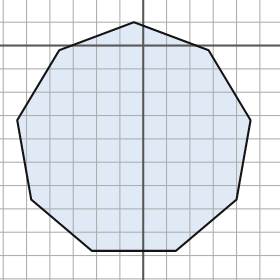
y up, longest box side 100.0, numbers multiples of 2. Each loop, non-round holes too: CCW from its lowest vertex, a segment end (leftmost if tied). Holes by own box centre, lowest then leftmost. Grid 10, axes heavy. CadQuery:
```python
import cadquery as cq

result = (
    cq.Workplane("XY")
    .moveTo(-22.0, -88.0)
    .lineTo(14.0, -88.0)
    .lineTo(40.0, -66.0)
    .lineTo(46.0, -32.0)
    .lineTo(28.0, -2.0)
    .lineTo(-4.0, 10.0)
    .lineTo(-36.0, -2.0)
    .lineTo(-54.0, -32.0)
    .lineTo(-48.0, -66.0)
    .close()
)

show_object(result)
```